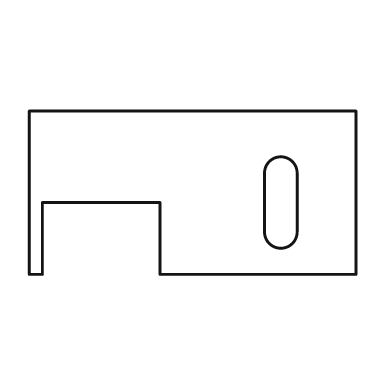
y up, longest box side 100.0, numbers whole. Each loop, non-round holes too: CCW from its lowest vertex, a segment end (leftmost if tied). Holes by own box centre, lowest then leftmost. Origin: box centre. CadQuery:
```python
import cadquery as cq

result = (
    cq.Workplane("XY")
    .moveTo(-50.0, -25.0)
    .lineTo(-46.0, -25.0)
    .lineTo(-46.0, -3.0)
    .lineTo(-10.0, -3.0)
    .lineTo(-10.0, -25.0)
    .lineTo(50.0, -25.0)
    .lineTo(50.0, 25.0)
    .lineTo(-50.0, 25.0)
    .close()
    .moveTo(22.0, -12.0)
    .threePointArc((27.0, -17.0), (32.0, -12.0))
    .lineTo(32.0, 6.0)
    .threePointArc((27.0, 11.0), (22.0, 6.0))
    .close()
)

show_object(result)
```